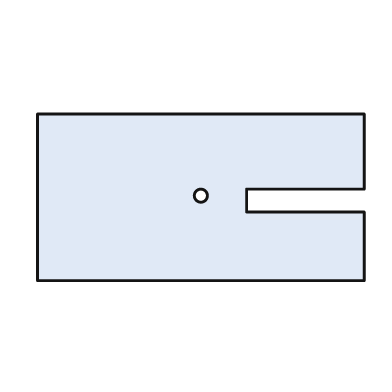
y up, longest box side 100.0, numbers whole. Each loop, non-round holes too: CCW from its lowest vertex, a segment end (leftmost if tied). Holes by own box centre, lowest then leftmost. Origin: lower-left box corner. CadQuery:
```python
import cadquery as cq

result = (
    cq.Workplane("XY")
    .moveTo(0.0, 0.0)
    .lineTo(100.0, 0.0)
    .lineTo(100.0, 21.0)
    .lineTo(64.0, 21.0)
    .lineTo(64.0, 28.0)
    .lineTo(100.0, 28.0)
    .lineTo(100.0, 51.0)
    .lineTo(0.0, 51.0)
    .close()
    .moveTo(50.0, 26.0)
    .circle(2.0)
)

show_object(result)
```